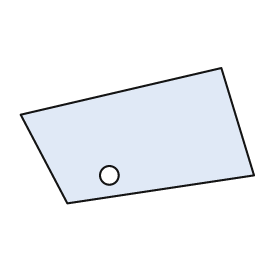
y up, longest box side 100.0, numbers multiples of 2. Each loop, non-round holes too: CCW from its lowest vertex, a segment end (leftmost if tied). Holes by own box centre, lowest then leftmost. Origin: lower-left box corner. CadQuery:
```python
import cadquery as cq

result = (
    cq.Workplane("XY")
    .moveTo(20.0, 0.0)
    .lineTo(100.0, 12.0)
    .lineTo(86.0, 58.0)
    .lineTo(0.0, 38.0)
    .close()
    .moveTo(38.0, 12.0)
    .circle(4.0)
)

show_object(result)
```